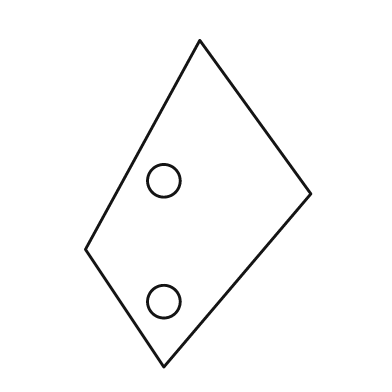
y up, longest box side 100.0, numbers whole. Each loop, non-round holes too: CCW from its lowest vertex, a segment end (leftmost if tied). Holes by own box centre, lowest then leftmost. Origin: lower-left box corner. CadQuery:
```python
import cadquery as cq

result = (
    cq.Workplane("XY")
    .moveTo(24.0, 0.0)
    .lineTo(69.0, 53.0)
    .lineTo(35.0, 100.0)
    .lineTo(0.0, 36.0)
    .close()
    .moveTo(24.0, 20.0)
    .circle(5.0)
    .moveTo(24.0, 57.0)
    .circle(5.0)
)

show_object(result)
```